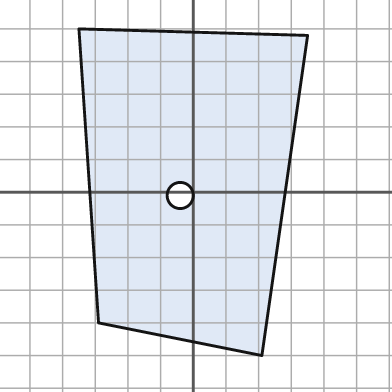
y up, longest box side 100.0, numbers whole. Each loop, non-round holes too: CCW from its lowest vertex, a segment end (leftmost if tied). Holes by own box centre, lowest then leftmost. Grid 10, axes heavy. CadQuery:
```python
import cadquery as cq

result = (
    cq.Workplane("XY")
    .moveTo(21.0, -50.0)
    .lineTo(35.0, 48.0)
    .lineTo(-35.0, 50.0)
    .lineTo(-29.0, -40.0)
    .close()
    .moveTo(-4.0, -1.0)
    .circle(4.0)
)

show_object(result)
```